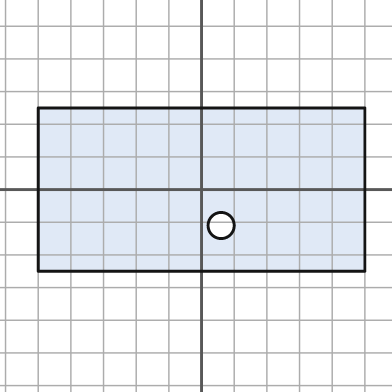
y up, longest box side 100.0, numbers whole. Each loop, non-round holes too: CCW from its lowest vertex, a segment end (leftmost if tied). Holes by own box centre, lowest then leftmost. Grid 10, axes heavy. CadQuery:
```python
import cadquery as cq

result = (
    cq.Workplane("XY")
    .moveTo(-50.0, -25.0)
    .lineTo(50.0, -25.0)
    .lineTo(50.0, 25.0)
    .lineTo(-50.0, 25.0)
    .close()
    .moveTo(6.0, -11.0)
    .circle(4.0)
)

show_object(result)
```